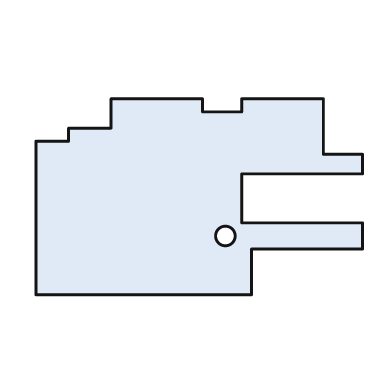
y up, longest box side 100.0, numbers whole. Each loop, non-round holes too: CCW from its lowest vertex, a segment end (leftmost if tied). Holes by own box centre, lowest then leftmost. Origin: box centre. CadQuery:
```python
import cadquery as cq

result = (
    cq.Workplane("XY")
    .moveTo(-50.0, -30.0)
    .lineTo(16.0, -30.0)
    .lineTo(16.0, -16.0)
    .lineTo(50.0, -16.0)
    .lineTo(50.0, -8.0)
    .lineTo(13.0, -8.0)
    .lineTo(13.0, 7.0)
    .lineTo(50.0, 7.0)
    .lineTo(50.0, 13.0)
    .lineTo(38.0, 13.0)
    .lineTo(38.0, 30.0)
    .lineTo(13.0, 30.0)
    .lineTo(13.0, 26.0)
    .lineTo(1.0, 26.0)
    .lineTo(1.0, 30.0)
    .lineTo(-27.0, 30.0)
    .lineTo(-27.0, 21.0)
    .lineTo(-40.0, 21.0)
    .lineTo(-40.0, 17.0)
    .lineTo(-50.0, 17.0)
    .close()
    .moveTo(8.0, -12.0)
    .circle(3.0)
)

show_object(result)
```